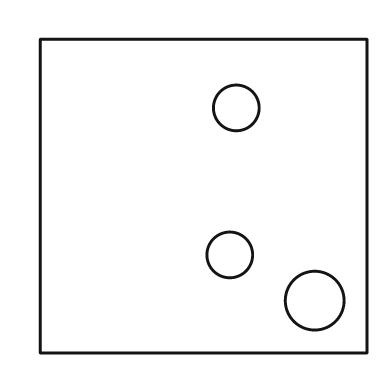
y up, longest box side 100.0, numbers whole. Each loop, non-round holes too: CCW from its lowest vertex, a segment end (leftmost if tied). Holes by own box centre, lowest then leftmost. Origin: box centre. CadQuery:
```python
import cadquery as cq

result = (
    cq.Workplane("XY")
    .moveTo(-50.0, -48.0)
    .lineTo(50.0, -48.0)
    .lineTo(50.0, 48.0)
    .lineTo(-50.0, 48.0)
    .close()
    .moveTo(34.0, -32.0)
    .circle(9.0)
    .moveTo(8.0, -18.0)
    .circle(7.0)
    .moveTo(10.0, 27.0)
    .circle(7.0)
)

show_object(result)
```